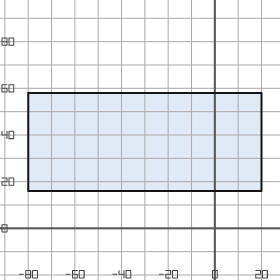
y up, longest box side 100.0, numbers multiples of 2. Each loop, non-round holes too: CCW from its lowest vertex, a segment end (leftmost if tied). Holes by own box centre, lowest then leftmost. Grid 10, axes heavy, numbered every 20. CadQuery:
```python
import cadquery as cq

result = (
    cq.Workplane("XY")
    .moveTo(-80.0, 16.0)
    .lineTo(20.0, 16.0)
    .lineTo(20.0, 58.0)
    .lineTo(-80.0, 58.0)
    .close()
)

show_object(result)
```